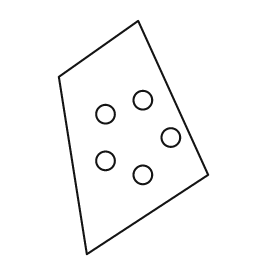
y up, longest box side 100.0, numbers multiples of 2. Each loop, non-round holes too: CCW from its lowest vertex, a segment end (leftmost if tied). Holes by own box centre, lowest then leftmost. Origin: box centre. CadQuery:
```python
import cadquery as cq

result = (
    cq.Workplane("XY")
    .moveTo(-20.0, -50.0)
    .lineTo(32.0, -16.0)
    .lineTo(2.0, 50.0)
    .lineTo(-32.0, 26.0)
    .close()
    .moveTo(4.0, -16.0)
    .circle(4.0)
    .moveTo(-12.0, -10.0)
    .circle(4.0)
    .moveTo(16.0, 0.0)
    .circle(4.0)
    .moveTo(-12.0, 10.0)
    .circle(4.0)
    .moveTo(4.0, 16.0)
    .circle(4.0)
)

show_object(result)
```